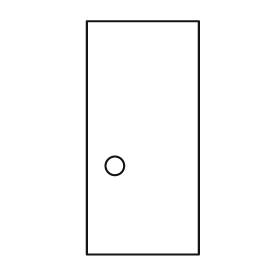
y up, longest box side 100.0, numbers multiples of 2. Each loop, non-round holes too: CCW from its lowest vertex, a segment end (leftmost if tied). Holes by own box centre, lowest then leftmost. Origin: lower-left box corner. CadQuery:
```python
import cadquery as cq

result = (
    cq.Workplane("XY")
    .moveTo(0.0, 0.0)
    .lineTo(48.0, 0.0)
    .lineTo(48.0, 100.0)
    .lineTo(0.0, 100.0)
    .close()
    .moveTo(12.0, 38.0)
    .circle(4.0)
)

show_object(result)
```